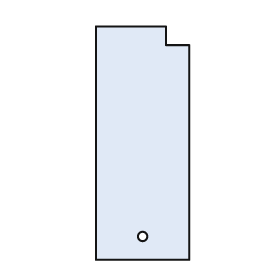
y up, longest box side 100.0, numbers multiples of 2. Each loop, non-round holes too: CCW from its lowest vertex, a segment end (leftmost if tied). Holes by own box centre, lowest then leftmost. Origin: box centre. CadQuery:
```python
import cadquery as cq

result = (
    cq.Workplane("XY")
    .moveTo(-20.0, -50.0)
    .lineTo(20.0, -50.0)
    .lineTo(20.0, 42.0)
    .lineTo(10.0, 42.0)
    .lineTo(10.0, 50.0)
    .lineTo(-20.0, 50.0)
    .close()
    .moveTo(0.0, -40.0)
    .circle(2.0)
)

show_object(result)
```